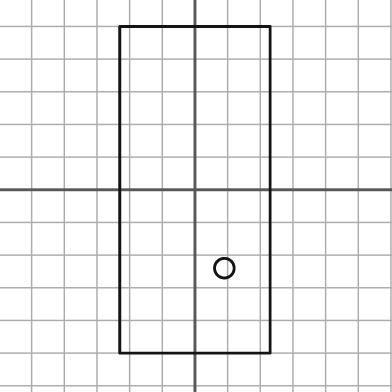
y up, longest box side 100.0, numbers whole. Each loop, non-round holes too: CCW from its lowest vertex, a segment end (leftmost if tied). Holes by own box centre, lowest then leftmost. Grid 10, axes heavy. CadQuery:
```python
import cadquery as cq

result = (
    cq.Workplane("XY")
    .moveTo(-23.0, -50.0)
    .lineTo(23.0, -50.0)
    .lineTo(23.0, 50.0)
    .lineTo(-23.0, 50.0)
    .close()
    .moveTo(9.0, -24.0)
    .circle(3.0)
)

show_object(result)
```